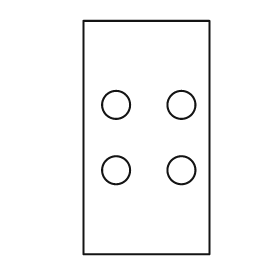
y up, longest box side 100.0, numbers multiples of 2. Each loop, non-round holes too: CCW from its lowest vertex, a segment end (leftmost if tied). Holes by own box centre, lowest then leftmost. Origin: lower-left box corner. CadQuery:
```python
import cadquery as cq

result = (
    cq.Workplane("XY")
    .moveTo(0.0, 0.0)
    .lineTo(54.0, 0.0)
    .lineTo(54.0, 100.0)
    .lineTo(0.0, 100.0)
    .close()
    .moveTo(14.0, 36.0)
    .circle(6.0)
    .moveTo(42.0, 36.0)
    .circle(6.0)
    .moveTo(14.0, 64.0)
    .circle(6.0)
    .moveTo(42.0, 64.0)
    .circle(6.0)
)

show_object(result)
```